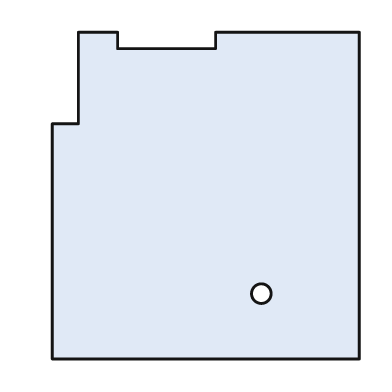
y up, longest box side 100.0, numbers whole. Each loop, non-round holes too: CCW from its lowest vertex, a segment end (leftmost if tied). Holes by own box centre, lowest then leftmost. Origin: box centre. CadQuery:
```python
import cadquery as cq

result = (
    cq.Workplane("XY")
    .moveTo(-47.0, -50.0)
    .lineTo(47.0, -50.0)
    .lineTo(47.0, 50.0)
    .lineTo(3.0, 50.0)
    .lineTo(3.0, 45.0)
    .lineTo(-27.0, 45.0)
    .lineTo(-27.0, 50.0)
    .lineTo(-39.0, 50.0)
    .lineTo(-39.0, 22.0)
    .lineTo(-47.0, 22.0)
    .close()
    .moveTo(17.0, -30.0)
    .circle(3.0)
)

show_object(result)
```